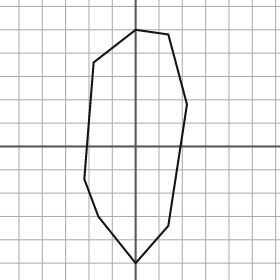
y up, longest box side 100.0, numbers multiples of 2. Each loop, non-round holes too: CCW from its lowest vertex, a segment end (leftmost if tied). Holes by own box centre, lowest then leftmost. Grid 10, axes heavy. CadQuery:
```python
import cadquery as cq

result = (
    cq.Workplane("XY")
    .moveTo(0.0, -50.0)
    .lineTo(14.0, -34.0)
    .lineTo(22.0, 18.0)
    .lineTo(14.0, 48.0)
    .lineTo(0.0, 50.0)
    .lineTo(-18.0, 36.0)
    .lineTo(-22.0, -14.0)
    .lineTo(-16.0, -30.0)
    .close()
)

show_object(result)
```